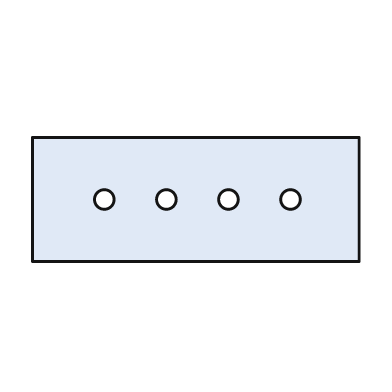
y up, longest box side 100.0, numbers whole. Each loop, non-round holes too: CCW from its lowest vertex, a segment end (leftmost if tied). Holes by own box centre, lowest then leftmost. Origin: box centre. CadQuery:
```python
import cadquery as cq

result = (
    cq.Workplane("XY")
    .moveTo(-50.0, -19.0)
    .lineTo(50.0, -19.0)
    .lineTo(50.0, 19.0)
    .lineTo(-50.0, 19.0)
    .close()
    .moveTo(-28.0, 0.0)
    .circle(3.0)
    .moveTo(-9.0, 0.0)
    .circle(3.0)
    .moveTo(10.0, 0.0)
    .circle(3.0)
    .moveTo(29.0, 0.0)
    .circle(3.0)
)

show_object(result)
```